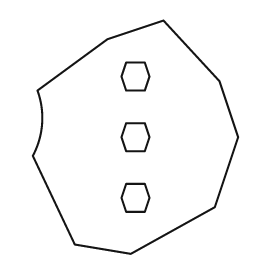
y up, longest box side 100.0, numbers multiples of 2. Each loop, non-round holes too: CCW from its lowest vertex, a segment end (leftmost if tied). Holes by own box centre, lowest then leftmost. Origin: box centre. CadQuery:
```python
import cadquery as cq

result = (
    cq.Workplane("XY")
    .moveTo(-2.0, -50.0)
    .lineTo(34.0, -30.0)
    .lineTo(44.0, 0.0)
    .lineTo(36.0, 24.0)
    .lineTo(12.0, 50.0)
    .lineTo(-12.0, 42.0)
    .lineTo(-42.0, 20.0)
    .threePointArc((-40.0, 6.0), (-44.0, -8.0))
    .lineTo(-26.0, -46.0)
    .close()
    .moveTo(-4.0, -32.0)
    .lineTo(4.0, -32.0)
    .lineTo(6.0, -26.0)
    .lineTo(4.0, -20.0)
    .lineTo(-4.0, -20.0)
    .lineTo(-6.0, -26.0)
    .close()
    .moveTo(-4.0, -6.0)
    .lineTo(4.0, -6.0)
    .lineTo(6.0, 0.0)
    .lineTo(4.0, 6.0)
    .lineTo(-4.0, 6.0)
    .lineTo(-6.0, 0.0)
    .close()
    .moveTo(-4.0, 20.0)
    .lineTo(4.0, 20.0)
    .lineTo(6.0, 26.0)
    .lineTo(4.0, 32.0)
    .lineTo(-4.0, 32.0)
    .lineTo(-6.0, 26.0)
    .close()
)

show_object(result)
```